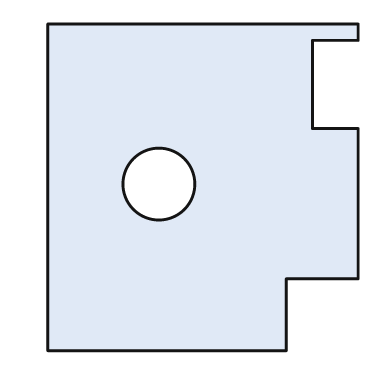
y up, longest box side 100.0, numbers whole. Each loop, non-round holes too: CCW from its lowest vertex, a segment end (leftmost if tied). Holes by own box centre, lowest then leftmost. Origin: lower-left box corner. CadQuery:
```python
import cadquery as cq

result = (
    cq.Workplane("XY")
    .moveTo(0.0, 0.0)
    .lineTo(73.0, 0.0)
    .lineTo(73.0, 22.0)
    .lineTo(95.0, 22.0)
    .lineTo(95.0, 68.0)
    .lineTo(81.0, 68.0)
    .lineTo(81.0, 95.0)
    .lineTo(95.0, 95.0)
    .lineTo(95.0, 100.0)
    .lineTo(0.0, 100.0)
    .close()
    .moveTo(34.0, 51.0)
    .circle(11.0)
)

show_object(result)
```